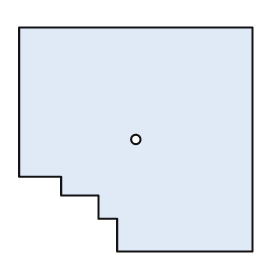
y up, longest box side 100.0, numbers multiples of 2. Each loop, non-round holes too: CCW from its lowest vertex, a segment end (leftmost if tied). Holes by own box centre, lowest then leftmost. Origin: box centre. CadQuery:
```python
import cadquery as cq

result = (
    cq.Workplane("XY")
    .moveTo(-8.0, -48.0)
    .lineTo(50.0, -48.0)
    .lineTo(50.0, 48.0)
    .lineTo(-50.0, 48.0)
    .lineTo(-50.0, -16.0)
    .lineTo(-32.0, -16.0)
    .lineTo(-32.0, -24.0)
    .lineTo(-16.0, -24.0)
    .lineTo(-16.0, -34.0)
    .lineTo(-8.0, -34.0)
    .close()
    .moveTo(0.0, 0.0)
    .circle(2.0)
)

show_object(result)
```